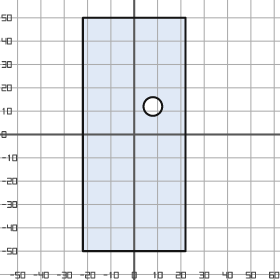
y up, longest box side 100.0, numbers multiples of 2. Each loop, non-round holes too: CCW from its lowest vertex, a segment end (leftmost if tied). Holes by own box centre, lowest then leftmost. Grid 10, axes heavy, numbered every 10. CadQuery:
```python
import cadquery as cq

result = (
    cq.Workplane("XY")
    .moveTo(-22.0, -50.0)
    .lineTo(22.0, -50.0)
    .lineTo(22.0, 50.0)
    .lineTo(-22.0, 50.0)
    .close()
    .moveTo(8.0, 12.0)
    .circle(4.0)
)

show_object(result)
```